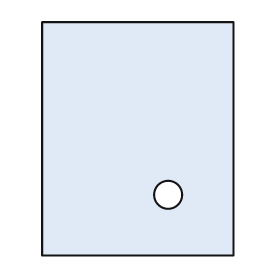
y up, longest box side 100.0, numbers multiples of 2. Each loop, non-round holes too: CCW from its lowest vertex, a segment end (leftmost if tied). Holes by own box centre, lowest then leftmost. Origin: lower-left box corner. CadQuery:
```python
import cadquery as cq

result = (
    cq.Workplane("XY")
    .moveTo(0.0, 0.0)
    .lineTo(82.0, 0.0)
    .lineTo(82.0, 100.0)
    .lineTo(0.0, 100.0)
    .close()
    .moveTo(54.0, 26.0)
    .circle(6.0)
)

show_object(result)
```